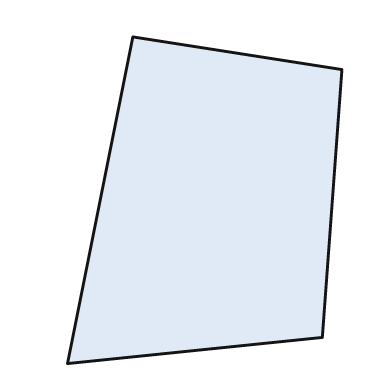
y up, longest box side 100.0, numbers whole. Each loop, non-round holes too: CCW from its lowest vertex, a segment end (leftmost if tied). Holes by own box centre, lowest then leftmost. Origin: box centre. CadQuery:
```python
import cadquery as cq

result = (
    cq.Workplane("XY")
    .moveTo(-42.0, -50.0)
    .lineTo(36.0, -42.0)
    .lineTo(42.0, 40.0)
    .lineTo(-22.0, 50.0)
    .close()
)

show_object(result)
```